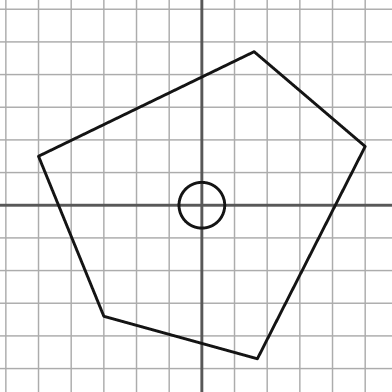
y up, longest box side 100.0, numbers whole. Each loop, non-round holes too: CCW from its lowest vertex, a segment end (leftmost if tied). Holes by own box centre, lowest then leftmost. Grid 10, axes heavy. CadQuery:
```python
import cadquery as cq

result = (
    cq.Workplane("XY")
    .moveTo(17.0, -47.0)
    .lineTo(50.0, 18.0)
    .lineTo(16.0, 47.0)
    .lineTo(-50.0, 15.0)
    .lineTo(-30.0, -34.0)
    .close()
    .moveTo(0.0, 0.0)
    .circle(7.0)
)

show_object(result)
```